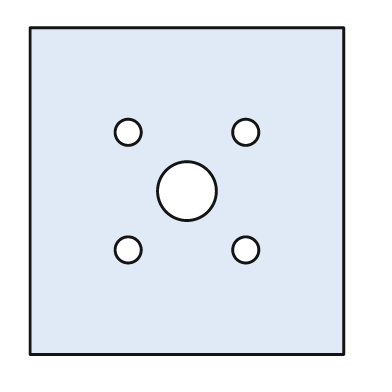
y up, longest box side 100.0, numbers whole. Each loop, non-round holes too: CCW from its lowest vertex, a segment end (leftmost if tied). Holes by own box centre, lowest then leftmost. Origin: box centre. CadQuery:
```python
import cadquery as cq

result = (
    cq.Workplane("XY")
    .moveTo(-48.0, -50.0)
    .lineTo(48.0, -50.0)
    .lineTo(48.0, 50.0)
    .lineTo(-48.0, 50.0)
    .close()
    .moveTo(-18.0, -18.0)
    .circle(4.0)
    .moveTo(18.0, -18.0)
    .circle(4.0)
    .moveTo(0.0, 0.0)
    .circle(9.0)
    .moveTo(-18.0, 18.0)
    .circle(4.0)
    .moveTo(18.0, 18.0)
    .circle(4.0)
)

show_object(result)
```